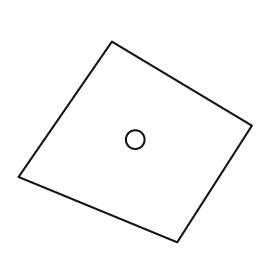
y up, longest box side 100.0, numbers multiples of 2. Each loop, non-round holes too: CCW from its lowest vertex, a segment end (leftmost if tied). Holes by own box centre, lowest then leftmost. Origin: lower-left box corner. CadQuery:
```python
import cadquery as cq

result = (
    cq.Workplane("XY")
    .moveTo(68.0, 0.0)
    .lineTo(100.0, 50.0)
    .lineTo(40.0, 86.0)
    .lineTo(0.0, 28.0)
    .close()
    .moveTo(50.0, 44.0)
    .circle(4.0)
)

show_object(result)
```